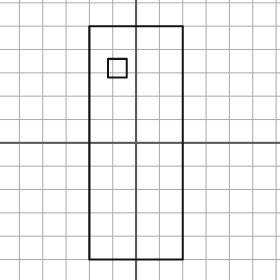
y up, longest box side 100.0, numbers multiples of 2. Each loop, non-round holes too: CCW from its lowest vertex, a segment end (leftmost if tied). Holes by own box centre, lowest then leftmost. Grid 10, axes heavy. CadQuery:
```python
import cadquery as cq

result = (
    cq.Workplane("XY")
    .moveTo(-20.0, -50.0)
    .lineTo(20.0, -50.0)
    .lineTo(20.0, 50.0)
    .lineTo(-20.0, 50.0)
    .close()
    .moveTo(-12.0, 28.0)
    .lineTo(-4.0, 28.0)
    .lineTo(-4.0, 36.0)
    .lineTo(-12.0, 36.0)
    .close()
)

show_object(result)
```